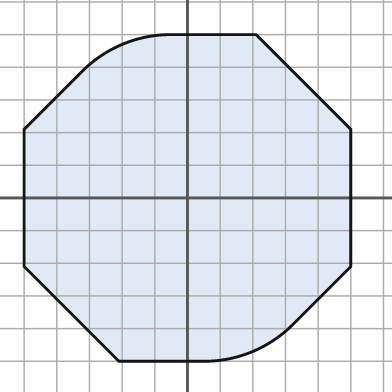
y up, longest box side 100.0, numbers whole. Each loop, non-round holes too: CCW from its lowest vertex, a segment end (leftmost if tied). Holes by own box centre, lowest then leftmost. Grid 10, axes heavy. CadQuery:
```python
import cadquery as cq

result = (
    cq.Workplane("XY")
    .moveTo(-21.0, -50.0)
    .lineTo(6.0, -50.0)
    .threePointArc((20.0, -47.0), (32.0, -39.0))
    .lineTo(50.0, -21.0)
    .lineTo(50.0, 21.0)
    .lineTo(21.0, 50.0)
    .lineTo(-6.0, 50.0)
    .threePointArc((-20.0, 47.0), (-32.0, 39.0))
    .lineTo(-50.0, 21.0)
    .lineTo(-50.0, -21.0)
    .close()
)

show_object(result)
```